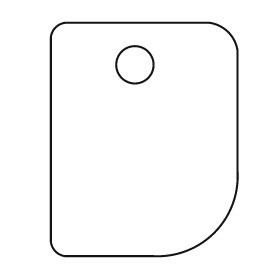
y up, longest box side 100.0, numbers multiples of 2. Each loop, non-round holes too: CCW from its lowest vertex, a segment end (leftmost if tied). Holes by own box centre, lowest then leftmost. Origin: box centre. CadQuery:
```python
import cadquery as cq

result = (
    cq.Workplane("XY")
    .moveTo(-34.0, -50.0)
    .lineTo(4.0, -50.0)
    .threePointArc((30.0, -40.0), (40.0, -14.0))
    .lineTo(40.0, 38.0)
    .threePointArc((36.0, 46.0), (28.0, 50.0))
    .lineTo(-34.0, 50.0)
    .threePointArc((-38.0, 48.0), (-40.0, 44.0))
    .lineTo(-40.0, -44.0)
    .threePointArc((-38.0, -48.0), (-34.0, -50.0))
    .close()
    .moveTo(-4.0, 32.0)
    .circle(8.0)
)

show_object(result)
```